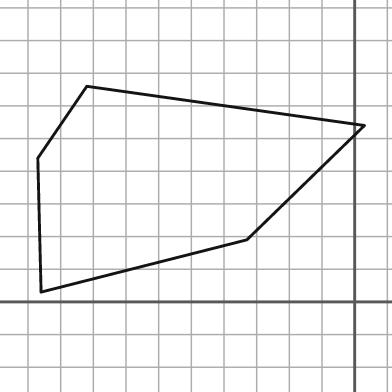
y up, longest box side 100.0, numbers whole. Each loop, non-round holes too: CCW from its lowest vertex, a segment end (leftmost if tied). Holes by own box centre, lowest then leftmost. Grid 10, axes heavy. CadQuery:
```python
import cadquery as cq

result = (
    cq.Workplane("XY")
    .moveTo(-96.0, 3.0)
    .lineTo(-33.0, 19.0)
    .lineTo(3.0, 54.0)
    .lineTo(-82.0, 66.0)
    .lineTo(-97.0, 44.0)
    .close()
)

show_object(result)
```